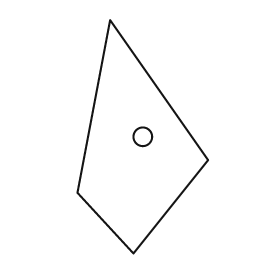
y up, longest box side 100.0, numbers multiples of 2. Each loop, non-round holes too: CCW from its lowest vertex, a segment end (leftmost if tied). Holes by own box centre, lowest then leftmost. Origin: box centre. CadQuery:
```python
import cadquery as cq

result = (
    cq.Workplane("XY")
    .moveTo(-4.0, -50.0)
    .lineTo(28.0, -10.0)
    .lineTo(-14.0, 50.0)
    .lineTo(-28.0, -24.0)
    .close()
    .moveTo(0.0, 0.0)
    .circle(4.0)
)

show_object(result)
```